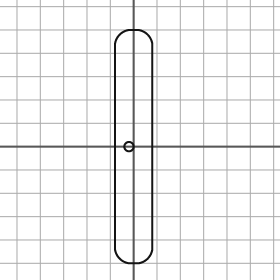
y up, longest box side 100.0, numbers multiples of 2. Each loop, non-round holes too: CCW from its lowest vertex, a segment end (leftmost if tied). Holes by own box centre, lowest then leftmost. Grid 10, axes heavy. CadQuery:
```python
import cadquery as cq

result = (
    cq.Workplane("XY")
    .moveTo(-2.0, -50.0)
    .lineTo(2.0, -50.0)
    .threePointArc((6.0, -48.0), (8.0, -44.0))
    .lineTo(8.0, 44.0)
    .threePointArc((6.0, 48.0), (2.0, 50.0))
    .lineTo(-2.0, 50.0)
    .threePointArc((-6.0, 48.0), (-8.0, 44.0))
    .lineTo(-8.0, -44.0)
    .threePointArc((-6.0, -48.0), (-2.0, -50.0))
    .close()
    .moveTo(-2.0, 0.0)
    .circle(2.0)
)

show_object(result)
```